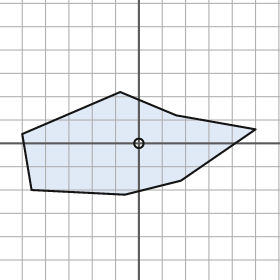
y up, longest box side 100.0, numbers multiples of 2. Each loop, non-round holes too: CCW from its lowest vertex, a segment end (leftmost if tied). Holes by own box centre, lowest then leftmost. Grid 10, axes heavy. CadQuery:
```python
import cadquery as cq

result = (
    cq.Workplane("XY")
    .moveTo(-6.0, -22.0)
    .lineTo(18.0, -16.0)
    .lineTo(50.0, 6.0)
    .lineTo(16.0, 12.0)
    .lineTo(-8.0, 22.0)
    .lineTo(-50.0, 4.0)
    .lineTo(-46.0, -20.0)
    .close()
    .moveTo(0.0, 0.0)
    .circle(2.0)
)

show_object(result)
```